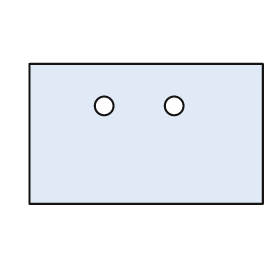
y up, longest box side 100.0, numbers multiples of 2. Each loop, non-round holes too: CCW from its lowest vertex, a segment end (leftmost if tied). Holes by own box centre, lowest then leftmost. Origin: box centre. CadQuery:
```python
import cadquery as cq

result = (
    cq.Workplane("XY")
    .moveTo(-50.0, -30.0)
    .lineTo(50.0, -30.0)
    .lineTo(50.0, 30.0)
    .lineTo(-50.0, 30.0)
    .close()
    .moveTo(-18.0, 12.0)
    .circle(4.0)
    .moveTo(12.0, 12.0)
    .circle(4.0)
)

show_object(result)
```